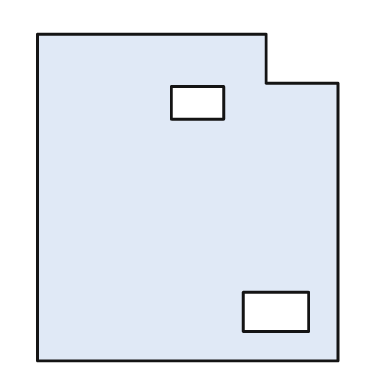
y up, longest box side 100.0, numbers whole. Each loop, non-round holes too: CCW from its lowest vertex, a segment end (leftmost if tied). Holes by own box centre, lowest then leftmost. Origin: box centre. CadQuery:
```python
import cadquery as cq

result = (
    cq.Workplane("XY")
    .moveTo(-46.0, -50.0)
    .lineTo(46.0, -50.0)
    .lineTo(46.0, 35.0)
    .lineTo(24.0, 35.0)
    .lineTo(24.0, 50.0)
    .lineTo(-46.0, 50.0)
    .close()
    .moveTo(17.0, -41.0)
    .lineTo(37.0, -41.0)
    .lineTo(37.0, -29.0)
    .lineTo(17.0, -29.0)
    .close()
    .moveTo(-5.0, 24.0)
    .lineTo(11.0, 24.0)
    .lineTo(11.0, 34.0)
    .lineTo(-5.0, 34.0)
    .close()
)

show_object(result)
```